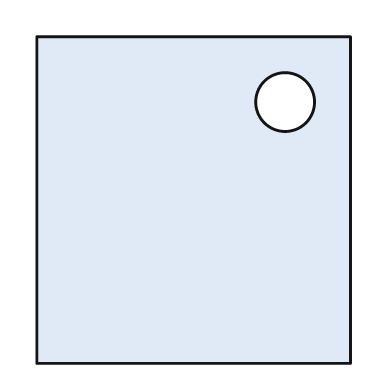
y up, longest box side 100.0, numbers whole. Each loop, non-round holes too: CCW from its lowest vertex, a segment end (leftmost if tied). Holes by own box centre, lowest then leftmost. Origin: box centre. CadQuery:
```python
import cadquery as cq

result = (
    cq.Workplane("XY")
    .moveTo(-48.0, -50.0)
    .lineTo(48.0, -50.0)
    .lineTo(48.0, 50.0)
    .lineTo(-48.0, 50.0)
    .close()
    .moveTo(28.0, 30.0)
    .circle(9.0)
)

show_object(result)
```